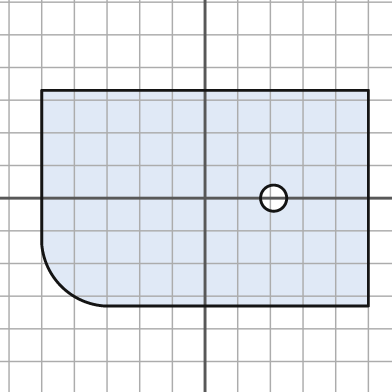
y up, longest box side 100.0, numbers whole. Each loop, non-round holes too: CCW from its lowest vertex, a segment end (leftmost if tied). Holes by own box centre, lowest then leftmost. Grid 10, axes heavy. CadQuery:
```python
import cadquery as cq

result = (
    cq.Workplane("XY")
    .moveTo(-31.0, -33.0)
    .lineTo(50.0, -33.0)
    .lineTo(50.0, 33.0)
    .lineTo(-50.0, 33.0)
    .lineTo(-50.0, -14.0)
    .threePointArc((-44.0, -27.0), (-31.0, -33.0))
    .close()
    .moveTo(21.0, 0.0)
    .circle(4.0)
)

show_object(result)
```